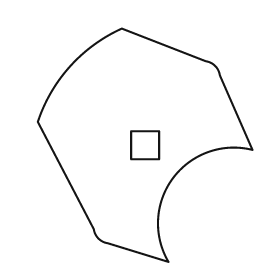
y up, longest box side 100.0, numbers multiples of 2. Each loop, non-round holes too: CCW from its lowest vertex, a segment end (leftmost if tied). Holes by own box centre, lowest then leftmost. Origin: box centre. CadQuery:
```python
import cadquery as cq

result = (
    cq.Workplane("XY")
    .moveTo(10.0, -50.0)
    .threePointArc((12.0, -14.0), (46.0, -2.0))
    .lineTo(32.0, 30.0)
    .threePointArc((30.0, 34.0), (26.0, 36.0))
    .lineTo(-10.0, 50.0)
    .threePointArc((-32.0, 34.0), (-46.0, 10.0))
    .lineTo(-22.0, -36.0)
    .threePointArc((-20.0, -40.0), (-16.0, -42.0))
    .close()
    .moveTo(-6.0, -6.0)
    .lineTo(6.0, -6.0)
    .lineTo(6.0, 6.0)
    .lineTo(-6.0, 6.0)
    .close()
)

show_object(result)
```